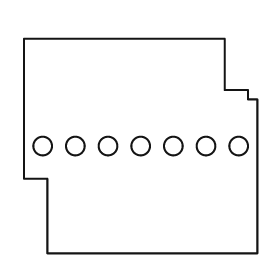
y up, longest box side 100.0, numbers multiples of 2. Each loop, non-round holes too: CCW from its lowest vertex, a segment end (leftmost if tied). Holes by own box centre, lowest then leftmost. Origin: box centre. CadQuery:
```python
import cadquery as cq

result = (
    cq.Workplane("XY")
    .moveTo(-40.0, -46.0)
    .lineTo(50.0, -46.0)
    .lineTo(50.0, 20.0)
    .lineTo(46.0, 20.0)
    .lineTo(46.0, 24.0)
    .lineTo(36.0, 24.0)
    .lineTo(36.0, 46.0)
    .lineTo(-50.0, 46.0)
    .lineTo(-50.0, -14.0)
    .lineTo(-40.0, -14.0)
    .close()
    .moveTo(-42.0, 0.0)
    .circle(4.0)
    .moveTo(-28.0, 0.0)
    .circle(4.0)
    .moveTo(-14.0, 0.0)
    .circle(4.0)
    .moveTo(0.0, 0.0)
    .circle(4.0)
    .moveTo(14.0, 0.0)
    .circle(4.0)
    .moveTo(28.0, 0.0)
    .circle(4.0)
    .moveTo(42.0, 0.0)
    .circle(4.0)
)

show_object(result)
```